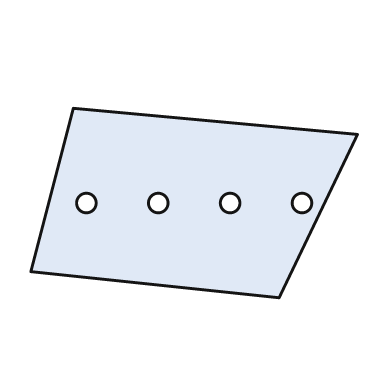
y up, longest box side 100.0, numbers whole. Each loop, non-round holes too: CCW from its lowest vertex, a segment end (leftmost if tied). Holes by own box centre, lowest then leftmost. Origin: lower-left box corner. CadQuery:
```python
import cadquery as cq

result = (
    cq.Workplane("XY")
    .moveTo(76.0, 0.0)
    .lineTo(100.0, 50.0)
    .lineTo(13.0, 58.0)
    .lineTo(0.0, 8.0)
    .close()
    .moveTo(17.0, 29.0)
    .circle(3.0)
    .moveTo(39.0, 29.0)
    .circle(3.0)
    .moveTo(61.0, 29.0)
    .circle(3.0)
    .moveTo(83.0, 29.0)
    .circle(3.0)
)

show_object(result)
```